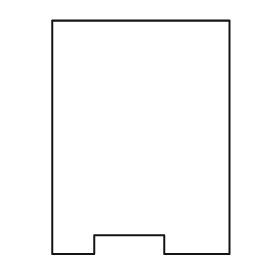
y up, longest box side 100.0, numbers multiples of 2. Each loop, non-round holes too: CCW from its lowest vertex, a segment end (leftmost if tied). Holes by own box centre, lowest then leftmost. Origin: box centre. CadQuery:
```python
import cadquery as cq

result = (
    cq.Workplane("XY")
    .moveTo(-38.0, -50.0)
    .lineTo(-20.0, -50.0)
    .lineTo(-20.0, -42.0)
    .lineTo(10.0, -42.0)
    .lineTo(10.0, -50.0)
    .lineTo(38.0, -50.0)
    .lineTo(38.0, 50.0)
    .lineTo(-38.0, 50.0)
    .close()
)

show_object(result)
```